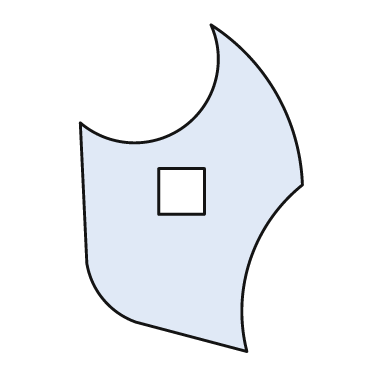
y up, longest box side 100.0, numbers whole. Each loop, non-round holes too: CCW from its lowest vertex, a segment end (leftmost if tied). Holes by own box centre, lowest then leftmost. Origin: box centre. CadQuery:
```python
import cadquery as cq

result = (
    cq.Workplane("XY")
    .moveTo(17.0, -50.0)
    .threePointArc((18.0, -22.0), (34.0, 1.0))
    .threePointArc((26.0, 29.0), (6.0, 50.0))
    .threePointArc((-2.0, 19.0), (-34.0, 20.0))
    .lineTo(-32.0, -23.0)
    .threePointArc((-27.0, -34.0), (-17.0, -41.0))
    .close()
    .moveTo(-10.0, -8.0)
    .lineTo(4.0, -8.0)
    .lineTo(4.0, 6.0)
    .lineTo(-10.0, 6.0)
    .close()
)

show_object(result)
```